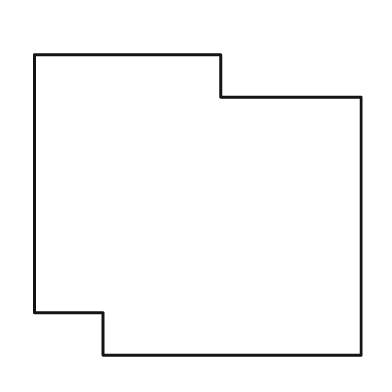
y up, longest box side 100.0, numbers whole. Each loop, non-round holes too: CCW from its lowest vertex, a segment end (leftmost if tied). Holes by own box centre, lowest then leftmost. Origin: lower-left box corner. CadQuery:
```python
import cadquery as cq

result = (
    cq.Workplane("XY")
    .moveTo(21.0, 0.0)
    .lineTo(100.0, 0.0)
    .lineTo(100.0, 79.0)
    .lineTo(57.0, 79.0)
    .lineTo(57.0, 92.0)
    .lineTo(0.0, 92.0)
    .lineTo(0.0, 13.0)
    .lineTo(21.0, 13.0)
    .close()
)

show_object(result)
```